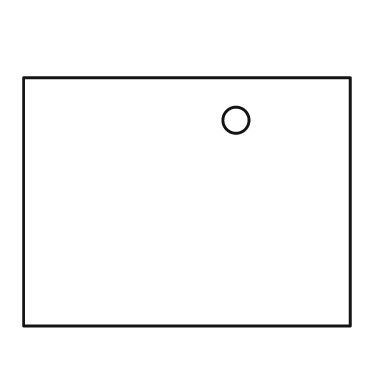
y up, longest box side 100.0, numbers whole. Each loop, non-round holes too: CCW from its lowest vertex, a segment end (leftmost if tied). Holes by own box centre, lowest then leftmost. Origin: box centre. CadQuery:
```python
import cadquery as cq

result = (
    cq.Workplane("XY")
    .moveTo(-50.0, -38.0)
    .lineTo(50.0, -38.0)
    .lineTo(50.0, 38.0)
    .lineTo(-50.0, 38.0)
    .close()
    .moveTo(15.0, 25.0)
    .circle(4.0)
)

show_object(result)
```